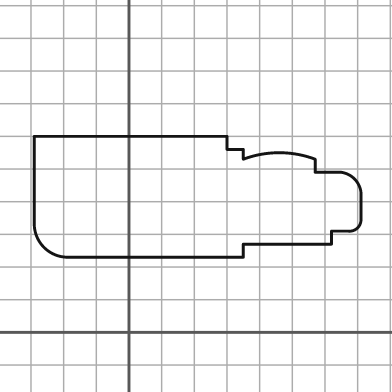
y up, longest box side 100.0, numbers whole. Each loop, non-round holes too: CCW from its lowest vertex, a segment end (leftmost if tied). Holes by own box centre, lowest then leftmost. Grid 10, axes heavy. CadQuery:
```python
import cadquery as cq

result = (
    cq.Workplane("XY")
    .moveTo(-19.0, 23.0)
    .lineTo(35.0, 23.0)
    .lineTo(35.0, 27.0)
    .lineTo(62.0, 27.0)
    .lineTo(62.0, 31.0)
    .lineTo(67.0, 31.0)
    .threePointArc((70.0, 32.0), (71.0, 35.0))
    .lineTo(71.0, 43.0)
    .threePointArc((69.0, 47.0), (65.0, 49.0))
    .lineTo(57.0, 49.0)
    .lineTo(57.0, 53.0)
    .threePointArc((46.0, 55.0), (35.0, 53.0))
    .lineTo(35.0, 56.0)
    .lineTo(30.0, 56.0)
    .lineTo(30.0, 60.0)
    .lineTo(-29.0, 60.0)
    .lineTo(-29.0, 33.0)
    .threePointArc((-26.0, 26.0), (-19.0, 23.0))
    .close()
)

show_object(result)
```